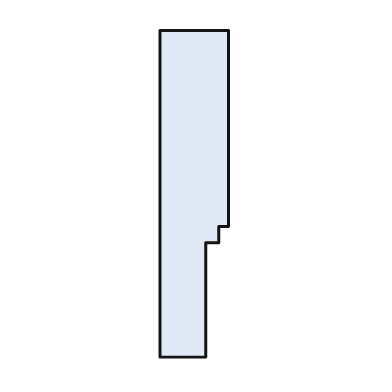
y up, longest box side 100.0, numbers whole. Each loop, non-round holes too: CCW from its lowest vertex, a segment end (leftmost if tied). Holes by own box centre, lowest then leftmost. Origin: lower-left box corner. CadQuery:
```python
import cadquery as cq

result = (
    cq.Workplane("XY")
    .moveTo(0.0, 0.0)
    .lineTo(14.0, 0.0)
    .lineTo(14.0, 35.0)
    .lineTo(18.0, 35.0)
    .lineTo(18.0, 40.0)
    .lineTo(21.0, 40.0)
    .lineTo(21.0, 100.0)
    .lineTo(0.0, 100.0)
    .close()
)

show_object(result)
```